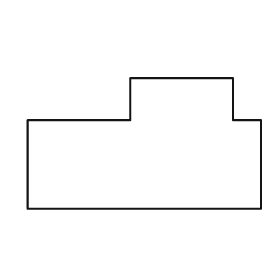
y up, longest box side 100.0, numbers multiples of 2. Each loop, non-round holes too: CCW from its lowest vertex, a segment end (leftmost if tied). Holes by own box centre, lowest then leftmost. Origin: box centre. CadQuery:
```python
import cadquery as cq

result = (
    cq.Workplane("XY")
    .moveTo(-50.0, -28.0)
    .lineTo(50.0, -28.0)
    .lineTo(50.0, 10.0)
    .lineTo(38.0, 10.0)
    .lineTo(38.0, 28.0)
    .lineTo(-6.0, 28.0)
    .lineTo(-6.0, 10.0)
    .lineTo(-50.0, 10.0)
    .close()
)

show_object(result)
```